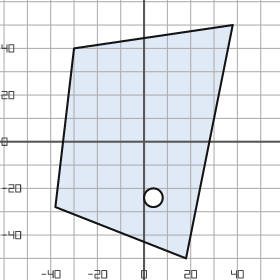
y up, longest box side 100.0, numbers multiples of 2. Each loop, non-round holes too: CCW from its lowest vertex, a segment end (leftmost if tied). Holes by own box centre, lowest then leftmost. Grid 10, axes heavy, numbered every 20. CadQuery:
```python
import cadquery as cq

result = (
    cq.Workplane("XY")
    .moveTo(18.0, -50.0)
    .lineTo(38.0, 50.0)
    .lineTo(-30.0, 40.0)
    .lineTo(-38.0, -28.0)
    .close()
    .moveTo(4.0, -24.0)
    .circle(4.0)
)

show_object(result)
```